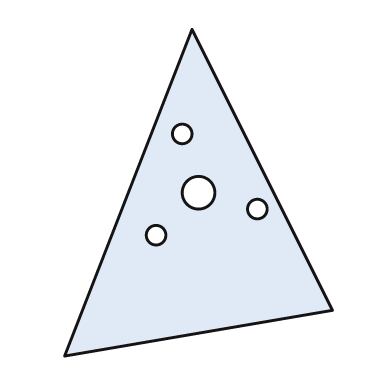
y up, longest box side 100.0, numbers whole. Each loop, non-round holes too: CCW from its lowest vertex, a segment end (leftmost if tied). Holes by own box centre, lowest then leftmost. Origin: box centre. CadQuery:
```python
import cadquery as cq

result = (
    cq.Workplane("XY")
    .moveTo(-41.0, -50.0)
    .lineTo(41.0, -36.0)
    .lineTo(-2.0, 50.0)
    .close()
    .moveTo(-13.0, -13.0)
    .circle(3.0)
    .moveTo(18.0, -5.0)
    .circle(3.0)
    .moveTo(0.0, 0.0)
    .circle(5.0)
    .moveTo(-5.0, 18.0)
    .circle(3.0)
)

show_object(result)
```